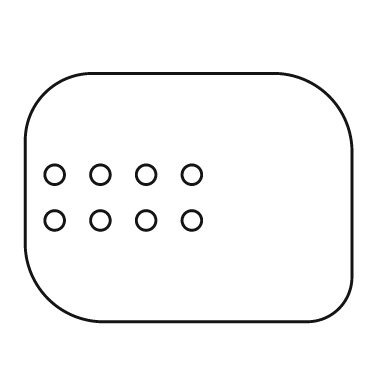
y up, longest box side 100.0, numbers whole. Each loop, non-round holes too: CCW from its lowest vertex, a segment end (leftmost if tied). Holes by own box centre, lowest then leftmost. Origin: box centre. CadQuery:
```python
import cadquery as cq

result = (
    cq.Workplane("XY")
    .moveTo(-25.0, -38.0)
    .lineTo(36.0, -38.0)
    .threePointArc((46.0, -34.0), (50.0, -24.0))
    .lineTo(50.0, 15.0)
    .threePointArc((43.0, 31.0), (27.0, 38.0))
    .lineTo(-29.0, 38.0)
    .threePointArc((-44.0, 32.0), (-50.0, 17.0))
    .lineTo(-50.0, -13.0)
    .threePointArc((-43.0, -31.0), (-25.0, -38.0))
    .close()
    .moveTo(-41.0, -7.0)
    .circle(3.0)
    .moveTo(-27.0, -7.0)
    .circle(3.0)
    .moveTo(-13.0, -7.0)
    .circle(3.0)
    .moveTo(1.0, -7.0)
    .circle(3.0)
    .moveTo(-41.0, 7.0)
    .circle(3.0)
    .moveTo(-27.0, 7.0)
    .circle(3.0)
    .moveTo(-13.0, 7.0)
    .circle(3.0)
    .moveTo(1.0, 7.0)
    .circle(3.0)
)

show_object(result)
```